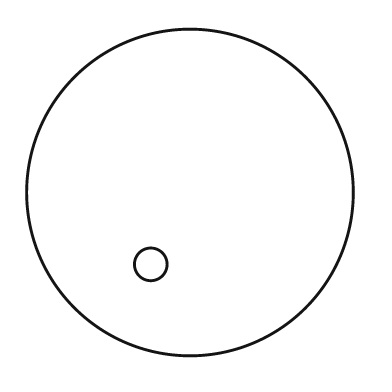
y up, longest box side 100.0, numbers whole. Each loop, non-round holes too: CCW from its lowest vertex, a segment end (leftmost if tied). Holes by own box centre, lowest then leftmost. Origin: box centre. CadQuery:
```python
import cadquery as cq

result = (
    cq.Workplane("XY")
    .moveTo(0.0, 0.0)
    .circle(50.0)
    .moveTo(-12.0, -22.0)
    .circle(5.0)
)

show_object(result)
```